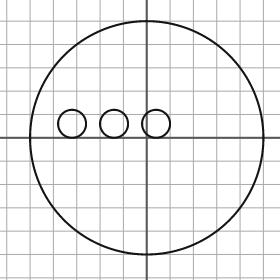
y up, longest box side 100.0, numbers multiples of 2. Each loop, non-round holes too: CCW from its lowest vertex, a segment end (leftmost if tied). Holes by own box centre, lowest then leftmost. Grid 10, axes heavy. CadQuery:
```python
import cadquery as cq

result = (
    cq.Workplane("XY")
    .moveTo(0.0, 0.0)
    .circle(50.0)
    .moveTo(-32.0, 6.0)
    .circle(6.0)
    .moveTo(-14.0, 6.0)
    .circle(6.0)
    .moveTo(4.0, 6.0)
    .circle(6.0)
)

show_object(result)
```